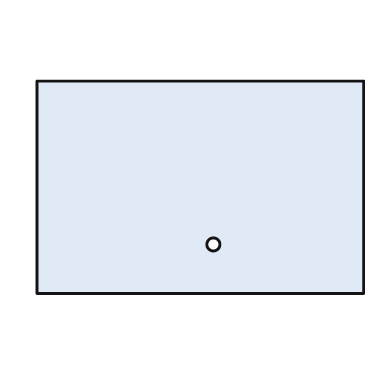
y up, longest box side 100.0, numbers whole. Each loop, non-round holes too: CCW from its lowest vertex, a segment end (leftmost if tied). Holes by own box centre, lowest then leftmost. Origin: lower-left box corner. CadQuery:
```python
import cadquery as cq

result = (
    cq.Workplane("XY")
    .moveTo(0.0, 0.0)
    .lineTo(100.0, 0.0)
    .lineTo(100.0, 65.0)
    .lineTo(0.0, 65.0)
    .close()
    .moveTo(54.0, 15.0)
    .circle(2.0)
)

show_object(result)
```